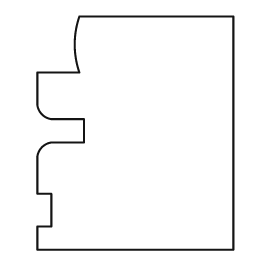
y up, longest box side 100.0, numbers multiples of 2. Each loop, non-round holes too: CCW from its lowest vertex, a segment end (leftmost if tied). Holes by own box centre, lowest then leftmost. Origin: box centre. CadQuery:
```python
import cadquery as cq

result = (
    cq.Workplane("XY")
    .moveTo(-42.0, -50.0)
    .lineTo(42.0, -50.0)
    .lineTo(42.0, 50.0)
    .lineTo(-24.0, 50.0)
    .threePointArc((-26.0, 38.0), (-24.0, 26.0))
    .lineTo(-42.0, 26.0)
    .lineTo(-42.0, 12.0)
    .threePointArc((-40.0, 8.0), (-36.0, 6.0))
    .lineTo(-22.0, 6.0)
    .lineTo(-22.0, -4.0)
    .lineTo(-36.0, -4.0)
    .threePointArc((-40.0, -6.0), (-42.0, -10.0))
    .lineTo(-42.0, -26.0)
    .lineTo(-36.0, -26.0)
    .lineTo(-36.0, -40.0)
    .lineTo(-42.0, -40.0)
    .close()
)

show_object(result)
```